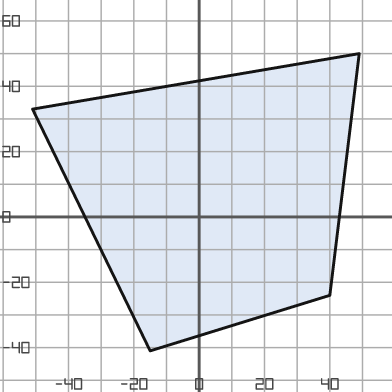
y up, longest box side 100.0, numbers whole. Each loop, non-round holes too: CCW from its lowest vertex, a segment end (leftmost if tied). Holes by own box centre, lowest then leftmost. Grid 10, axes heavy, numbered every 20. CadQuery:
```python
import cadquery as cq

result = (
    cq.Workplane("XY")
    .moveTo(-15.0, -41.0)
    .lineTo(40.0, -24.0)
    .lineTo(49.0, 50.0)
    .lineTo(-51.0, 33.0)
    .close()
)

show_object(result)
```